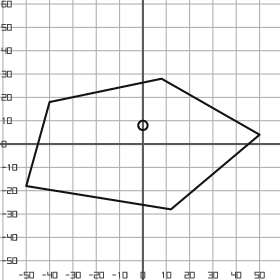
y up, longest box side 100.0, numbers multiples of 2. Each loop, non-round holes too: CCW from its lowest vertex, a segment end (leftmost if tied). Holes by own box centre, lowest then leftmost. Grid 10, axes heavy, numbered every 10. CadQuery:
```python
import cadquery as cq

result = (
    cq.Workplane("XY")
    .moveTo(12.0, -28.0)
    .lineTo(50.0, 4.0)
    .lineTo(8.0, 28.0)
    .lineTo(-40.0, 18.0)
    .lineTo(-50.0, -18.0)
    .close()
    .moveTo(0.0, 8.0)
    .circle(2.0)
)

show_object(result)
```